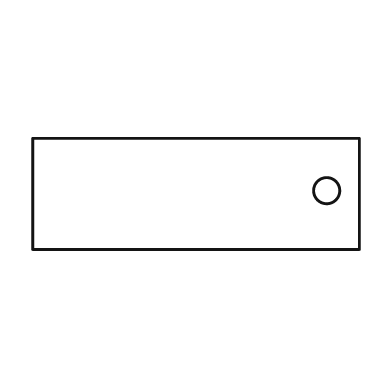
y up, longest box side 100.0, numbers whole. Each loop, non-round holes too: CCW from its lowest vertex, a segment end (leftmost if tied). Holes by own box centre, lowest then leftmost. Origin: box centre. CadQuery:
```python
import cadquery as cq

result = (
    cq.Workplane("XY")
    .moveTo(-50.0, -17.0)
    .lineTo(50.0, -17.0)
    .lineTo(50.0, 17.0)
    .lineTo(-50.0, 17.0)
    .close()
    .moveTo(40.0, 1.0)
    .circle(4.0)
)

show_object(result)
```